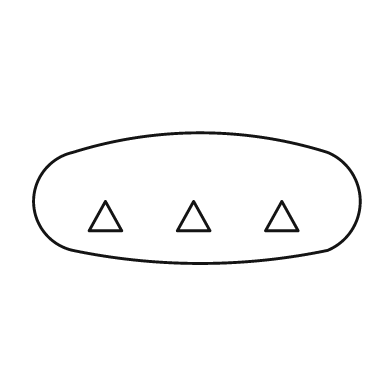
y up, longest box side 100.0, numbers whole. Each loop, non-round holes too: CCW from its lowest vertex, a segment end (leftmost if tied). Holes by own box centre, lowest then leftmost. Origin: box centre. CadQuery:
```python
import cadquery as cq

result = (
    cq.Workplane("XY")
    .moveTo(-38.0, -16.0)
    .threePointArc((1.0, -20.0), (40.0, -16.0))
    .threePointArc((50.0, -1.0), (40.0, 14.0))
    .threePointArc((1.0, 20.0), (-38.0, 14.0))
    .threePointArc((-50.0, -1.0), (-38.0, -16.0))
    .close()
    .moveTo(-33.0, -10.0)
    .lineTo(-23.0, -10.0)
    .lineTo(-28.0, -1.0)
    .close()
    .moveTo(-6.0, -10.0)
    .lineTo(4.0, -10.0)
    .lineTo(-1.0, -1.0)
    .close()
    .moveTo(21.0, -10.0)
    .lineTo(31.0, -10.0)
    .lineTo(26.0, -1.0)
    .close()
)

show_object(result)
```